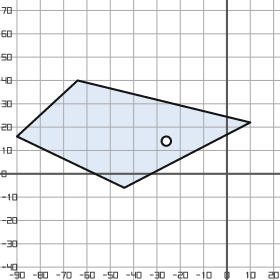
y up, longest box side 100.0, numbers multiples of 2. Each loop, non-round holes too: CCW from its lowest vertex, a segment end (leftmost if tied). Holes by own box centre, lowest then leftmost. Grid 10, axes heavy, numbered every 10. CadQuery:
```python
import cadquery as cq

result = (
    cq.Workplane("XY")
    .moveTo(-44.0, -6.0)
    .lineTo(10.0, 22.0)
    .lineTo(-64.0, 40.0)
    .lineTo(-90.0, 16.0)
    .close()
    .moveTo(-26.0, 14.0)
    .circle(2.0)
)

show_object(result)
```